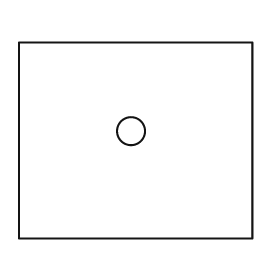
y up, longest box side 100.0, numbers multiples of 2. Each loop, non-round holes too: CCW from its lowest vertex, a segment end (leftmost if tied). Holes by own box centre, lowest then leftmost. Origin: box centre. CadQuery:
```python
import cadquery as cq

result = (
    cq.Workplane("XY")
    .moveTo(-50.0, -42.0)
    .lineTo(50.0, -42.0)
    .lineTo(50.0, 42.0)
    .lineTo(-50.0, 42.0)
    .close()
    .moveTo(-2.0, 4.0)
    .circle(6.0)
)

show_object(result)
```